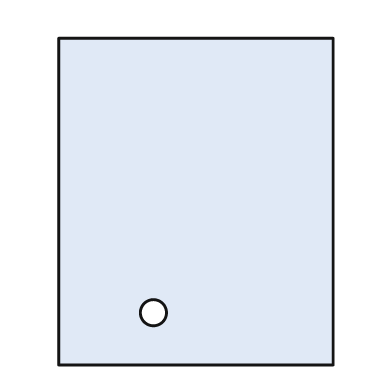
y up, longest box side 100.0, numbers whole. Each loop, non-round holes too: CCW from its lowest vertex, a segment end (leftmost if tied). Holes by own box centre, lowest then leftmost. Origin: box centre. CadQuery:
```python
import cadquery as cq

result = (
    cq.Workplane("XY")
    .moveTo(-42.0, -50.0)
    .lineTo(42.0, -50.0)
    .lineTo(42.0, 50.0)
    .lineTo(-42.0, 50.0)
    .close()
    .moveTo(-13.0, -34.0)
    .circle(4.0)
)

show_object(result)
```